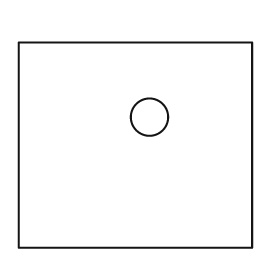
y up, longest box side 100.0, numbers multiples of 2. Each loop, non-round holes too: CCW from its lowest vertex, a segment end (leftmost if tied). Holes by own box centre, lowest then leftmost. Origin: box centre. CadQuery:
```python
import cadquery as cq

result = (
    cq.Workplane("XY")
    .moveTo(-50.0, -44.0)
    .lineTo(50.0, -44.0)
    .lineTo(50.0, 44.0)
    .lineTo(-50.0, 44.0)
    .close()
    .moveTo(6.0, 12.0)
    .circle(8.0)
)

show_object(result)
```